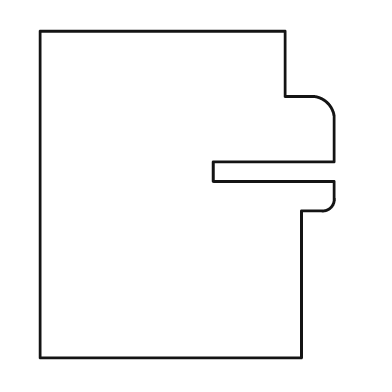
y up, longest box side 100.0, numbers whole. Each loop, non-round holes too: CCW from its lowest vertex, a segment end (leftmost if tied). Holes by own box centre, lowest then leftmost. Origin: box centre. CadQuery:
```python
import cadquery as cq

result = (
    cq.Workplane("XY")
    .moveTo(-45.0, -50.0)
    .lineTo(35.0, -50.0)
    .lineTo(35.0, -5.0)
    .lineTo(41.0, -5.0)
    .threePointArc((44.0, -4.0), (45.0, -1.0))
    .lineTo(45.0, 4.0)
    .lineTo(8.0, 4.0)
    .lineTo(8.0, 10.0)
    .lineTo(45.0, 10.0)
    .lineTo(45.0, 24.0)
    .threePointArc((43.0, 28.0), (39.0, 30.0))
    .lineTo(30.0, 30.0)
    .lineTo(30.0, 50.0)
    .lineTo(-45.0, 50.0)
    .close()
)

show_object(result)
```